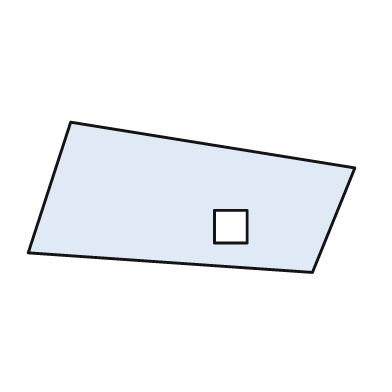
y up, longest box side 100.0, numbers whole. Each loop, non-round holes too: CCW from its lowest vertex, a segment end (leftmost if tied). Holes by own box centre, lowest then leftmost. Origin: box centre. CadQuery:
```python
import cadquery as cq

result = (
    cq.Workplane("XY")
    .moveTo(37.0, -23.0)
    .lineTo(50.0, 9.0)
    .lineTo(-37.0, 23.0)
    .lineTo(-50.0, -17.0)
    .close()
    .moveTo(7.0, -14.0)
    .lineTo(17.0, -14.0)
    .lineTo(17.0, -4.0)
    .lineTo(7.0, -4.0)
    .close()
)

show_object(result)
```